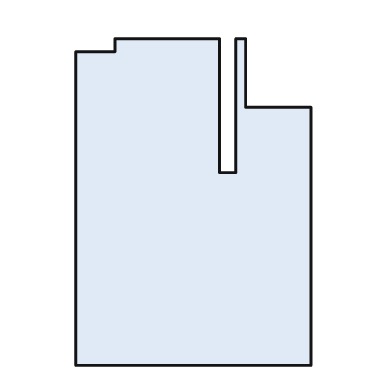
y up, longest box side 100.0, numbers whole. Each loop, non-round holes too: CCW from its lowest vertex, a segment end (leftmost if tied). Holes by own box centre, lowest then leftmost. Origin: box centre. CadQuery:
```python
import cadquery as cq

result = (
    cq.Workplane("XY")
    .moveTo(-36.0, -50.0)
    .lineTo(36.0, -50.0)
    .lineTo(36.0, 29.0)
    .lineTo(16.0, 29.0)
    .lineTo(16.0, 50.0)
    .lineTo(13.0, 50.0)
    .lineTo(13.0, 9.0)
    .lineTo(8.0, 9.0)
    .lineTo(8.0, 50.0)
    .lineTo(-24.0, 50.0)
    .lineTo(-24.0, 46.0)
    .lineTo(-36.0, 46.0)
    .close()
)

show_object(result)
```